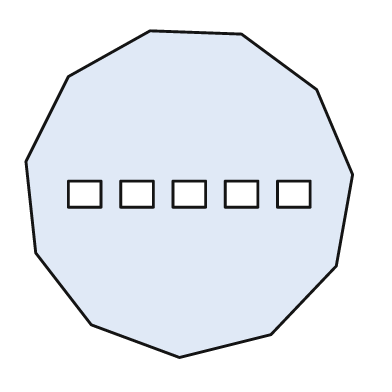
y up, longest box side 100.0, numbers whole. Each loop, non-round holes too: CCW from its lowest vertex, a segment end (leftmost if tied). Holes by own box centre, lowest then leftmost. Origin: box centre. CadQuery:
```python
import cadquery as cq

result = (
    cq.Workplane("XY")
    .moveTo(-3.0, -50.0)
    .lineTo(25.0, -43.0)
    .lineTo(45.0, -22.0)
    .lineTo(50.0, 6.0)
    .lineTo(39.0, 32.0)
    .lineTo(16.0, 49.0)
    .lineTo(-12.0, 50.0)
    .lineTo(-37.0, 36.0)
    .lineTo(-50.0, 10.0)
    .lineTo(-47.0, -18.0)
    .lineTo(-30.0, -40.0)
    .close()
    .moveTo(-37.0, -4.0)
    .lineTo(-27.0, -4.0)
    .lineTo(-27.0, 4.0)
    .lineTo(-37.0, 4.0)
    .close()
    .moveTo(-21.0, -4.0)
    .lineTo(-11.0, -4.0)
    .lineTo(-11.0, 4.0)
    .lineTo(-21.0, 4.0)
    .close()
    .moveTo(-5.0, -4.0)
    .lineTo(5.0, -4.0)
    .lineTo(5.0, 4.0)
    .lineTo(-5.0, 4.0)
    .close()
    .moveTo(11.0, -4.0)
    .lineTo(21.0, -4.0)
    .lineTo(21.0, 4.0)
    .lineTo(11.0, 4.0)
    .close()
    .moveTo(27.0, -4.0)
    .lineTo(37.0, -4.0)
    .lineTo(37.0, 4.0)
    .lineTo(27.0, 4.0)
    .close()
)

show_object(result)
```